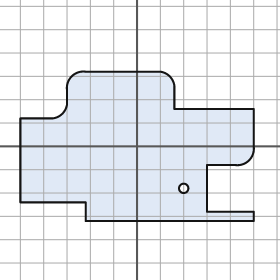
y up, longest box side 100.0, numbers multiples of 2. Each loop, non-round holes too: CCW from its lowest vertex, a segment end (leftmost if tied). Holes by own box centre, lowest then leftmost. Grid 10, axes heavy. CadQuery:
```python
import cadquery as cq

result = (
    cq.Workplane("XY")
    .moveTo(-22.0, -32.0)
    .lineTo(50.0, -32.0)
    .lineTo(50.0, -28.0)
    .lineTo(30.0, -28.0)
    .lineTo(30.0, -8.0)
    .lineTo(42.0, -8.0)
    .threePointArc((48.0, -6.0), (50.0, 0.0))
    .lineTo(50.0, 16.0)
    .lineTo(16.0, 16.0)
    .lineTo(16.0, 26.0)
    .threePointArc((14.0, 30.0), (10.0, 32.0))
    .lineTo(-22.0, 32.0)
    .threePointArc((-28.0, 30.0), (-30.0, 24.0))
    .lineTo(-30.0, 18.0)
    .threePointArc((-32.0, 14.0), (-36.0, 12.0))
    .lineTo(-50.0, 12.0)
    .lineTo(-50.0, -24.0)
    .lineTo(-22.0, -24.0)
    .close()
    .moveTo(20.0, -18.0)
    .circle(2.0)
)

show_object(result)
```